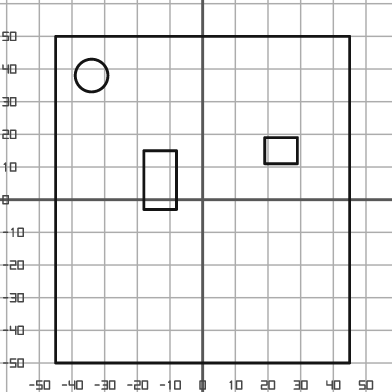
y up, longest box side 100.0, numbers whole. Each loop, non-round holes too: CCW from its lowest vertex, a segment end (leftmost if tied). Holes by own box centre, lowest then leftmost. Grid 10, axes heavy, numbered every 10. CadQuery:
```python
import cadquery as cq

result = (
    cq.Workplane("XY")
    .moveTo(-45.0, -50.0)
    .lineTo(45.0, -50.0)
    .lineTo(45.0, 50.0)
    .lineTo(-45.0, 50.0)
    .close()
    .moveTo(-18.0, -3.0)
    .lineTo(-8.0, -3.0)
    .lineTo(-8.0, 15.0)
    .lineTo(-18.0, 15.0)
    .close()
    .moveTo(19.0, 11.0)
    .lineTo(29.0, 11.0)
    .lineTo(29.0, 19.0)
    .lineTo(19.0, 19.0)
    .close()
    .moveTo(-34.0, 38.0)
    .circle(5.0)
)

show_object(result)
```